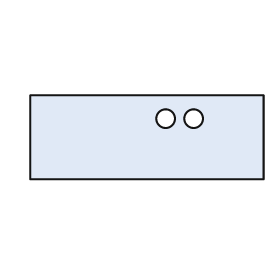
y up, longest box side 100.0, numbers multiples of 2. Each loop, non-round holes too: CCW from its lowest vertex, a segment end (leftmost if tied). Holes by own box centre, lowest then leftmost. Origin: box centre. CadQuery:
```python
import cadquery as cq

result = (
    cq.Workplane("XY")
    .moveTo(-50.0, -18.0)
    .lineTo(50.0, -18.0)
    .lineTo(50.0, 18.0)
    .lineTo(-50.0, 18.0)
    .close()
    .moveTo(8.0, 8.0)
    .circle(4.0)
    .moveTo(20.0, 8.0)
    .circle(4.0)
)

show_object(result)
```